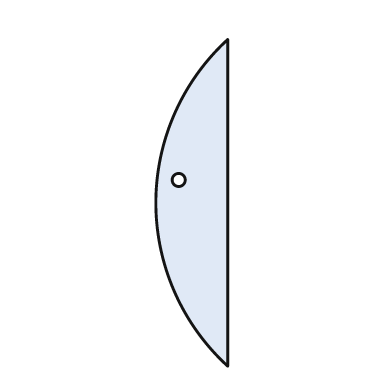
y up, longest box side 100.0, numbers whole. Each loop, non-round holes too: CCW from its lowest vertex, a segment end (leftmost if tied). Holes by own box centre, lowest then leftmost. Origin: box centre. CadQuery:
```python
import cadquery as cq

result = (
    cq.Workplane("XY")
    .moveTo(11.0, -50.0)
    .lineTo(11.0, 50.0)
    .threePointArc((-11.0, 0.0), (11.0, -50.0))
    .close()
    .moveTo(-4.0, 7.0)
    .circle(2.0)
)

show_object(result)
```